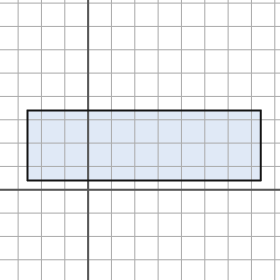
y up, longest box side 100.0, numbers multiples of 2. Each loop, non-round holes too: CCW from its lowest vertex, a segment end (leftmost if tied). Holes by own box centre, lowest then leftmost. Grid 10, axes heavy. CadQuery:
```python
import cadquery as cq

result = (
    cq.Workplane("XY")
    .moveTo(-26.0, 4.0)
    .lineTo(74.0, 4.0)
    .lineTo(74.0, 34.0)
    .lineTo(-26.0, 34.0)
    .close()
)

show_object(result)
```